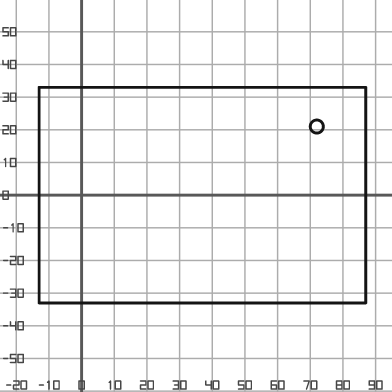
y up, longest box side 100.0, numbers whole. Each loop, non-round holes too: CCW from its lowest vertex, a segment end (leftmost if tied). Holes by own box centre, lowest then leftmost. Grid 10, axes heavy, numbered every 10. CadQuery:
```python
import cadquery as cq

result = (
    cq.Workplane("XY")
    .moveTo(-13.0, -33.0)
    .lineTo(87.0, -33.0)
    .lineTo(87.0, 33.0)
    .lineTo(-13.0, 33.0)
    .close()
    .moveTo(72.0, 21.0)
    .circle(2.0)
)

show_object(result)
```